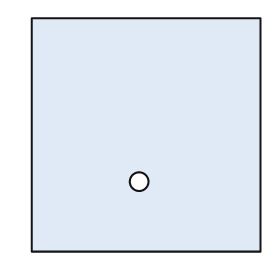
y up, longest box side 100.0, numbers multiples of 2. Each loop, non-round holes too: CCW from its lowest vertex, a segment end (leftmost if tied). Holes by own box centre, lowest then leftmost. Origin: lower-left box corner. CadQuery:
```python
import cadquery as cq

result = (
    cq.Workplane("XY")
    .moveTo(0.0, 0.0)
    .lineTo(98.0, 0.0)
    .lineTo(98.0, 100.0)
    .lineTo(0.0, 100.0)
    .close()
    .moveTo(46.0, 30.0)
    .circle(4.0)
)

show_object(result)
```